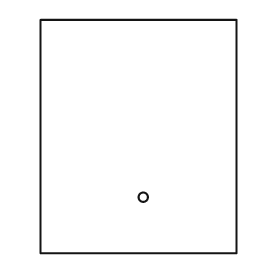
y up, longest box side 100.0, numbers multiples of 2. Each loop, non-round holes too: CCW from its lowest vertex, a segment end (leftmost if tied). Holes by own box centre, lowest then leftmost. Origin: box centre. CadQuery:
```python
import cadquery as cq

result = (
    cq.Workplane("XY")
    .moveTo(-42.0, -50.0)
    .lineTo(42.0, -50.0)
    .lineTo(42.0, 50.0)
    .lineTo(-42.0, 50.0)
    .close()
    .moveTo(2.0, -26.0)
    .circle(2.0)
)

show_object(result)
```